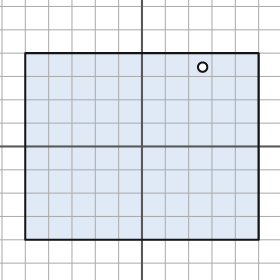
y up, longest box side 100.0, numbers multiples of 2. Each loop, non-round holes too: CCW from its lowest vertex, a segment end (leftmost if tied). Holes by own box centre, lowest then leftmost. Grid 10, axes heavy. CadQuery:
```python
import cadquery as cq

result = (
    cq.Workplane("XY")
    .moveTo(-50.0, -40.0)
    .lineTo(50.0, -40.0)
    .lineTo(50.0, 40.0)
    .lineTo(-50.0, 40.0)
    .close()
    .moveTo(26.0, 34.0)
    .circle(2.0)
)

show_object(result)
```